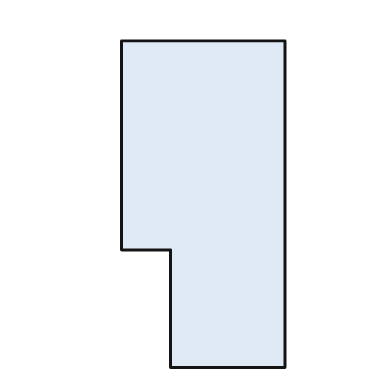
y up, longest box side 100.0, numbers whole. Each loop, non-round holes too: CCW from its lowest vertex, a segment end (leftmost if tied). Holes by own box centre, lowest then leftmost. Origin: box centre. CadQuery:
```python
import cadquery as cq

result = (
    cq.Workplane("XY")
    .moveTo(-10.0, -50.0)
    .lineTo(25.0, -50.0)
    .lineTo(25.0, 50.0)
    .lineTo(-25.0, 50.0)
    .lineTo(-25.0, -14.0)
    .lineTo(-10.0, -14.0)
    .close()
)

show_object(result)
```